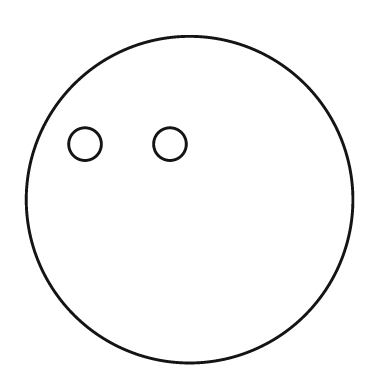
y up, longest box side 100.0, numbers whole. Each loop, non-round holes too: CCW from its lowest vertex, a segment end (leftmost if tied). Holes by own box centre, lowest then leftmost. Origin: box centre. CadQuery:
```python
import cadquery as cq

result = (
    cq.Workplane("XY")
    .moveTo(0.0, 0.0)
    .circle(50.0)
    .moveTo(-32.0, 17.0)
    .circle(5.0)
    .moveTo(-6.0, 17.0)
    .circle(5.0)
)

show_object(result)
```